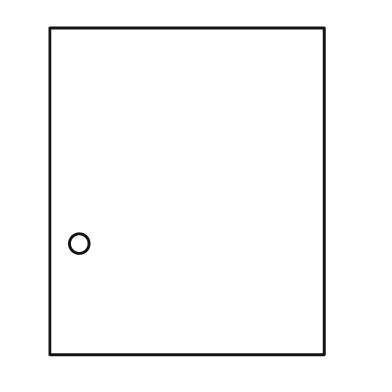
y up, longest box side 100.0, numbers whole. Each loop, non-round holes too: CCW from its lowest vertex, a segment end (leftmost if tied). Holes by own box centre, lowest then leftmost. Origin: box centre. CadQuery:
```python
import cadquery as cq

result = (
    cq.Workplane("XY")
    .moveTo(-42.0, -50.0)
    .lineTo(42.0, -50.0)
    .lineTo(42.0, 50.0)
    .lineTo(-42.0, 50.0)
    .close()
    .moveTo(-33.0, -16.0)
    .circle(3.0)
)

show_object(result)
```